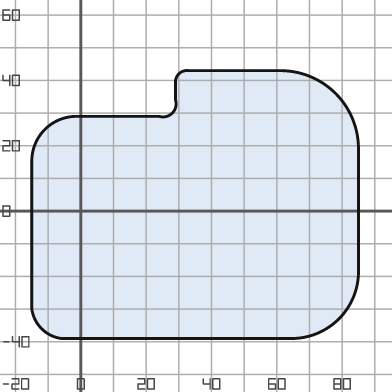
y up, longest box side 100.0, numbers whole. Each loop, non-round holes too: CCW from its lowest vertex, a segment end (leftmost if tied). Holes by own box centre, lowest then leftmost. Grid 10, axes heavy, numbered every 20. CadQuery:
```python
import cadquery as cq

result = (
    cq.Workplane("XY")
    .moveTo(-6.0, -39.0)
    .lineTo(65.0, -39.0)
    .threePointArc((79.0, -33.0), (85.0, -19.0))
    .lineTo(85.0, 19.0)
    .threePointArc((78.0, 36.0), (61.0, 43.0))
    .lineTo(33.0, 43.0)
    .threePointArc((30.0, 42.0), (29.0, 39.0))
    .lineTo(29.0, 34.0)
    .threePointArc((28.0, 30.0), (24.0, 29.0))
    .lineTo(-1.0, 29.0)
    .threePointArc((-11.0, 25.0), (-15.0, 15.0))
    .lineTo(-15.0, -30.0)
    .threePointArc((-12.0, -36.0), (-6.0, -39.0))
    .close()
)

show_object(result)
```